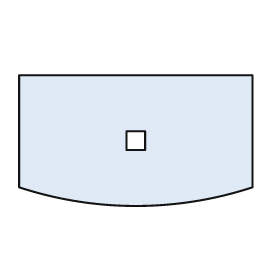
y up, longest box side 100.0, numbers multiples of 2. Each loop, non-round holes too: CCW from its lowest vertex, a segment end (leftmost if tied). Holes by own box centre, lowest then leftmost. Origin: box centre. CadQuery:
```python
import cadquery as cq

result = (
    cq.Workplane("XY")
    .moveTo(-50.0, -20.0)
    .threePointArc((0.0, -28.0), (50.0, -20.0))
    .lineTo(50.0, 28.0)
    .lineTo(-50.0, 28.0)
    .close()
    .moveTo(-4.0, -4.0)
    .lineTo(4.0, -4.0)
    .lineTo(4.0, 4.0)
    .lineTo(-4.0, 4.0)
    .close()
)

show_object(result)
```